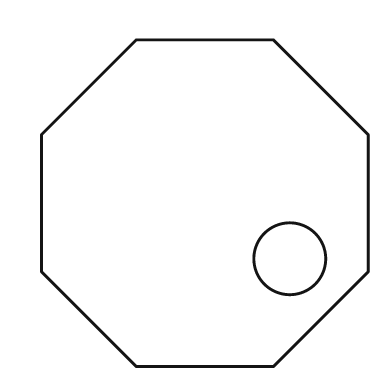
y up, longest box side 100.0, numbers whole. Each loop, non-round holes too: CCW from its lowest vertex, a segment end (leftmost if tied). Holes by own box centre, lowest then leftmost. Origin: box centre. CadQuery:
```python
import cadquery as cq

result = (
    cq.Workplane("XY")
    .moveTo(-21.0, -50.0)
    .lineTo(21.0, -50.0)
    .lineTo(50.0, -21.0)
    .lineTo(50.0, 21.0)
    .lineTo(21.0, 50.0)
    .lineTo(-21.0, 50.0)
    .lineTo(-50.0, 21.0)
    .lineTo(-50.0, -21.0)
    .close()
    .moveTo(26.0, -17.0)
    .circle(11.0)
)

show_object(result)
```